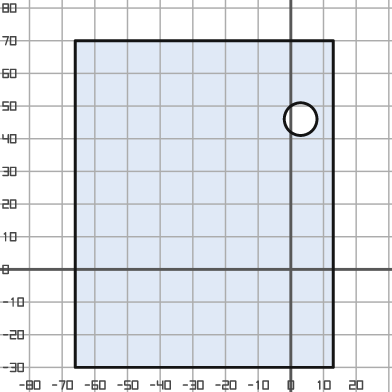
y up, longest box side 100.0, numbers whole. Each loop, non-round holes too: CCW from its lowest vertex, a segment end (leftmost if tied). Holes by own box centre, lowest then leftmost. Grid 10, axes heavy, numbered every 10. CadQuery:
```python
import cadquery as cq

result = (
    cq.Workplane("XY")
    .moveTo(-66.0, -30.0)
    .lineTo(13.0, -30.0)
    .lineTo(13.0, 70.0)
    .lineTo(-66.0, 70.0)
    .close()
    .moveTo(3.0, 46.0)
    .circle(5.0)
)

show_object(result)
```